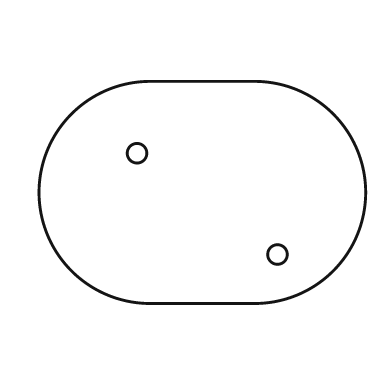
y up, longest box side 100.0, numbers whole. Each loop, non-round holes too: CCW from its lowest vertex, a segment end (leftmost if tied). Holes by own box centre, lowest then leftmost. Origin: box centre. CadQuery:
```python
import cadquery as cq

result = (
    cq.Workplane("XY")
    .moveTo(-16.0, -34.0)
    .lineTo(16.0, -34.0)
    .threePointArc((50.0, 0.0), (16.0, 34.0))
    .lineTo(-16.0, 34.0)
    .threePointArc((-50.0, 0.0), (-16.0, -34.0))
    .close()
    .moveTo(23.0, -19.0)
    .circle(3.0)
    .moveTo(-20.0, 12.0)
    .circle(3.0)
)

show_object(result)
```